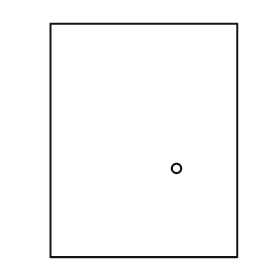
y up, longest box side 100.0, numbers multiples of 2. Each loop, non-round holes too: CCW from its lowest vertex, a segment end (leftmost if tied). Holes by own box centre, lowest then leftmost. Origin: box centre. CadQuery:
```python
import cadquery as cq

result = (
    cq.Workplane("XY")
    .moveTo(-40.0, -50.0)
    .lineTo(40.0, -50.0)
    .lineTo(40.0, 50.0)
    .lineTo(-40.0, 50.0)
    .close()
    .moveTo(14.0, -12.0)
    .circle(2.0)
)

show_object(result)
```